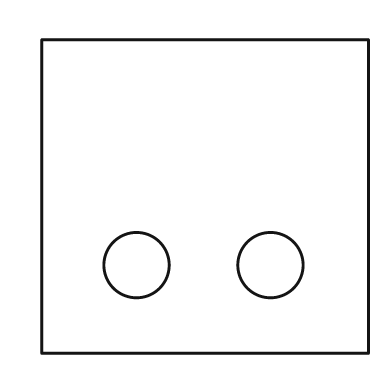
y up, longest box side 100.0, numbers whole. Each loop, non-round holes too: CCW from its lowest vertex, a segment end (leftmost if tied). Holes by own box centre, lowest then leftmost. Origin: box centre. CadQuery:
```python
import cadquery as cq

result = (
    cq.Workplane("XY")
    .moveTo(-50.0, -48.0)
    .lineTo(50.0, -48.0)
    .lineTo(50.0, 48.0)
    .lineTo(-50.0, 48.0)
    .close()
    .moveTo(-21.0, -21.0)
    .circle(10.0)
    .moveTo(20.0, -21.0)
    .circle(10.0)
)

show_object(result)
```